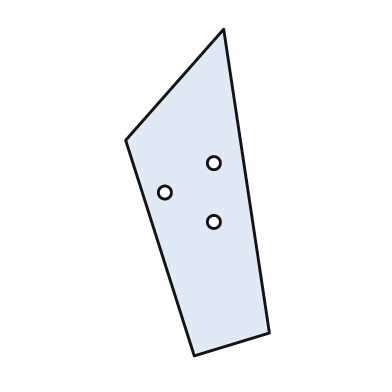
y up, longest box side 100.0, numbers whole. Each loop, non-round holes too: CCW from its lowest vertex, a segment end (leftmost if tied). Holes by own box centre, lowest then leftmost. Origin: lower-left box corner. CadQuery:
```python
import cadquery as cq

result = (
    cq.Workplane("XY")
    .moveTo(21.0, 0.0)
    .lineTo(44.0, 7.0)
    .lineTo(30.0, 100.0)
    .lineTo(0.0, 66.0)
    .close()
    .moveTo(27.0, 41.0)
    .circle(2.0)
    .moveTo(12.0, 50.0)
    .circle(2.0)
    .moveTo(27.0, 59.0)
    .circle(2.0)
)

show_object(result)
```